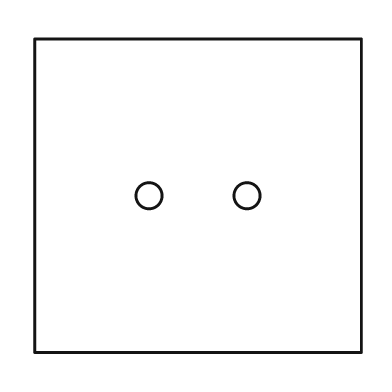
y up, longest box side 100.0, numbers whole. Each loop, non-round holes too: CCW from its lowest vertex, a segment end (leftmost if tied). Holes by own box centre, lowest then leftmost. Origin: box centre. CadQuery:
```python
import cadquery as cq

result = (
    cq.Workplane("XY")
    .moveTo(-50.0, -48.0)
    .lineTo(50.0, -48.0)
    .lineTo(50.0, 48.0)
    .lineTo(-50.0, 48.0)
    .close()
    .moveTo(-15.0, 0.0)
    .circle(4.0)
    .moveTo(15.0, 0.0)
    .circle(4.0)
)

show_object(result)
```